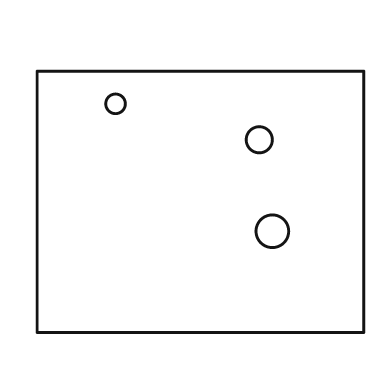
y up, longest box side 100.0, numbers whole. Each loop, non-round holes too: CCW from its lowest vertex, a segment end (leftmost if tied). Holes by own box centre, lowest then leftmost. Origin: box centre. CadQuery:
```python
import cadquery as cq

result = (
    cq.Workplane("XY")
    .moveTo(-50.0, -40.0)
    .lineTo(50.0, -40.0)
    .lineTo(50.0, 40.0)
    .lineTo(-50.0, 40.0)
    .close()
    .moveTo(22.0, -9.0)
    .circle(5.0)
    .moveTo(18.0, 19.0)
    .circle(4.0)
    .moveTo(-26.0, 30.0)
    .circle(3.0)
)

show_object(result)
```